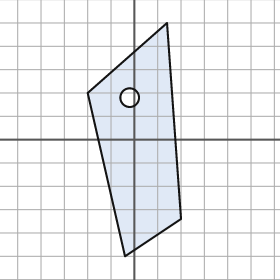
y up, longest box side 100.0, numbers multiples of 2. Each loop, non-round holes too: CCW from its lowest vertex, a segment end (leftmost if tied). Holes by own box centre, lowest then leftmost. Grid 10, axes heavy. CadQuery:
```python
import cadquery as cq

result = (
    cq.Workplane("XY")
    .moveTo(-4.0, -50.0)
    .lineTo(20.0, -34.0)
    .lineTo(14.0, 50.0)
    .lineTo(-20.0, 20.0)
    .close()
    .moveTo(-2.0, 18.0)
    .circle(4.0)
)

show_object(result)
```